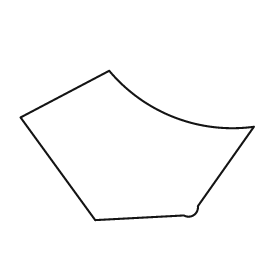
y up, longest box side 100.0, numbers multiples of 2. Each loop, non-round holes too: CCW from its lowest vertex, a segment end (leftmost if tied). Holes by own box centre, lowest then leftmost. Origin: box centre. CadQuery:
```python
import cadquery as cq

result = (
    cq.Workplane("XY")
    .moveTo(-18.0, -32.0)
    .lineTo(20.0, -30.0)
    .threePointArc((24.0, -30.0), (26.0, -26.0))
    .lineTo(50.0, 8.0)
    .threePointArc((16.0, 12.0), (-12.0, 32.0))
    .lineTo(-50.0, 12.0)
    .close()
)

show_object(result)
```